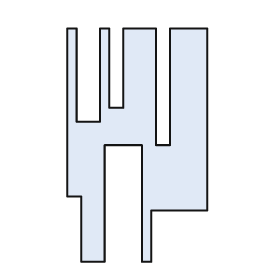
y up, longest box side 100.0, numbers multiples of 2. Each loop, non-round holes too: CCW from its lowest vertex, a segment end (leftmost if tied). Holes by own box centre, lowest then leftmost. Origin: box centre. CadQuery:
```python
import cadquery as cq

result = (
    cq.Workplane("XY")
    .moveTo(-24.0, -50.0)
    .lineTo(-14.0, -50.0)
    .lineTo(-14.0, 0.0)
    .lineTo(2.0, 0.0)
    .lineTo(2.0, -50.0)
    .lineTo(6.0, -50.0)
    .lineTo(6.0, -28.0)
    .lineTo(30.0, -28.0)
    .lineTo(30.0, 50.0)
    .lineTo(14.0, 50.0)
    .lineTo(14.0, 0.0)
    .lineTo(8.0, 0.0)
    .lineTo(8.0, 50.0)
    .lineTo(-6.0, 50.0)
    .lineTo(-6.0, 16.0)
    .lineTo(-12.0, 16.0)
    .lineTo(-12.0, 50.0)
    .lineTo(-16.0, 50.0)
    .lineTo(-16.0, 10.0)
    .lineTo(-26.0, 10.0)
    .lineTo(-26.0, 50.0)
    .lineTo(-30.0, 50.0)
    .lineTo(-30.0, -22.0)
    .lineTo(-24.0, -22.0)
    .close()
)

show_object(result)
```